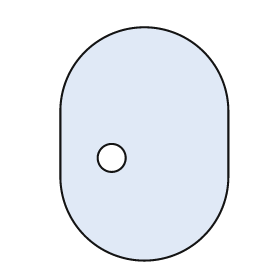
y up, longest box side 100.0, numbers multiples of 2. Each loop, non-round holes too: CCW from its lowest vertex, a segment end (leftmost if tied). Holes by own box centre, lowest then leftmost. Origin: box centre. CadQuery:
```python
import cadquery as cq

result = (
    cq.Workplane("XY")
    .moveTo(-36.0, -14.0)
    .threePointArc((0.0, -50.0), (36.0, -14.0))
    .lineTo(36.0, 14.0)
    .threePointArc((0.0, 50.0), (-36.0, 14.0))
    .close()
    .moveTo(-14.0, -6.0)
    .circle(6.0)
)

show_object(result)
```